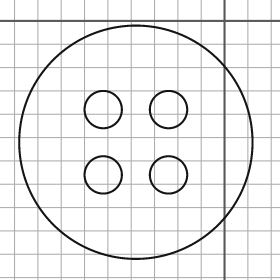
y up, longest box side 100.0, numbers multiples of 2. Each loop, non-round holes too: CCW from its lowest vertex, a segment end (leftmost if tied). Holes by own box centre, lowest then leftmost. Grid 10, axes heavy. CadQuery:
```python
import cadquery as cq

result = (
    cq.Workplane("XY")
    .moveTo(-38.0, -52.0)
    .circle(50.0)
    .moveTo(-52.0, -66.0)
    .circle(8.0)
    .moveTo(-24.0, -66.0)
    .circle(8.0)
    .moveTo(-52.0, -38.0)
    .circle(8.0)
    .moveTo(-24.0, -38.0)
    .circle(8.0)
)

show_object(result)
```